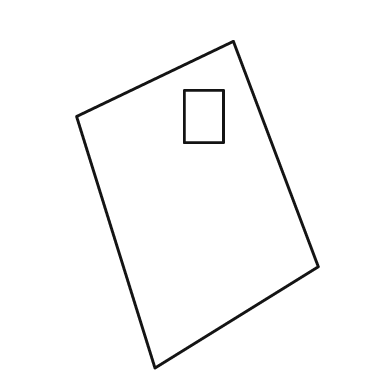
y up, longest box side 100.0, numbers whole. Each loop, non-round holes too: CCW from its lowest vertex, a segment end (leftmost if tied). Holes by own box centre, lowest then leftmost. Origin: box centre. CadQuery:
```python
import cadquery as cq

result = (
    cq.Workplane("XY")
    .moveTo(-13.0, -50.0)
    .lineTo(37.0, -19.0)
    .lineTo(11.0, 50.0)
    .lineTo(-37.0, 27.0)
    .close()
    .moveTo(-4.0, 19.0)
    .lineTo(8.0, 19.0)
    .lineTo(8.0, 35.0)
    .lineTo(-4.0, 35.0)
    .close()
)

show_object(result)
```